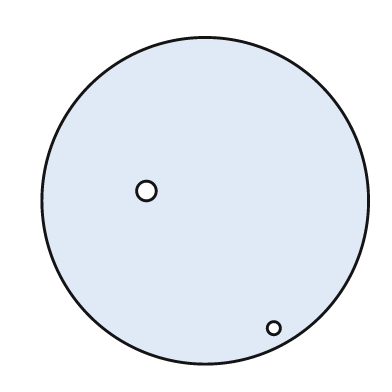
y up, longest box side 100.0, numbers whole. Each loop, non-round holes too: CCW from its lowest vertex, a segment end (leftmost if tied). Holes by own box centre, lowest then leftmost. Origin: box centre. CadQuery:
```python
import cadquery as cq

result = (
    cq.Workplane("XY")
    .moveTo(0.0, 0.0)
    .circle(50.0)
    .moveTo(21.0, -39.0)
    .circle(2.0)
    .moveTo(-18.0, 3.0)
    .circle(3.0)
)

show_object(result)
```